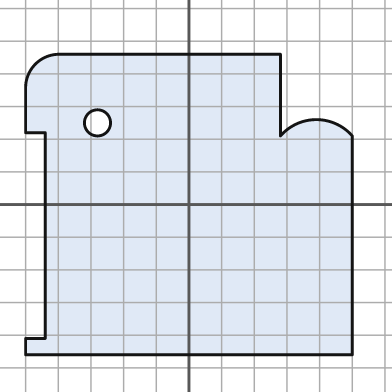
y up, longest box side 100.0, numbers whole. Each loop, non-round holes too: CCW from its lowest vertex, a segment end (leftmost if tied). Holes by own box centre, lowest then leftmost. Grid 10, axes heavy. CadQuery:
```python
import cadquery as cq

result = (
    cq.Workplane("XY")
    .moveTo(-50.0, -46.0)
    .lineTo(50.0, -46.0)
    .lineTo(50.0, 21.0)
    .threePointArc((39.0, 26.0), (28.0, 21.0))
    .lineTo(28.0, 46.0)
    .lineTo(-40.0, 46.0)
    .threePointArc((-47.0, 43.0), (-50.0, 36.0))
    .lineTo(-50.0, 22.0)
    .lineTo(-44.0, 22.0)
    .lineTo(-44.0, -41.0)
    .lineTo(-50.0, -41.0)
    .close()
    .moveTo(-28.0, 25.0)
    .circle(4.0)
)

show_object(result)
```